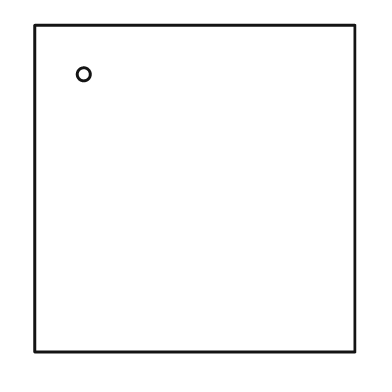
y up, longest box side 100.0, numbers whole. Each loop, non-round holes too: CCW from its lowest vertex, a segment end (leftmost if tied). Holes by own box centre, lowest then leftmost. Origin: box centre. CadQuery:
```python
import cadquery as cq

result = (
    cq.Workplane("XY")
    .moveTo(-49.0, -50.0)
    .lineTo(49.0, -50.0)
    .lineTo(49.0, 50.0)
    .lineTo(-49.0, 50.0)
    .close()
    .moveTo(-34.0, 35.0)
    .circle(2.0)
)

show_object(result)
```